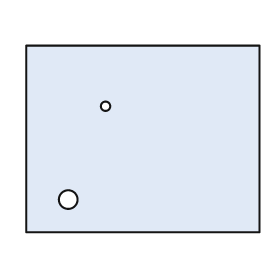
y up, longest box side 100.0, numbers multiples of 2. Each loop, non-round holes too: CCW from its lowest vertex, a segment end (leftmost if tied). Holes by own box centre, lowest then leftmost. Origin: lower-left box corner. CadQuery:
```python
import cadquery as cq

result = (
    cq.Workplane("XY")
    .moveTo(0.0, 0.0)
    .lineTo(100.0, 0.0)
    .lineTo(100.0, 80.0)
    .lineTo(0.0, 80.0)
    .close()
    .moveTo(18.0, 14.0)
    .circle(4.0)
    .moveTo(34.0, 54.0)
    .circle(2.0)
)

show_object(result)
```